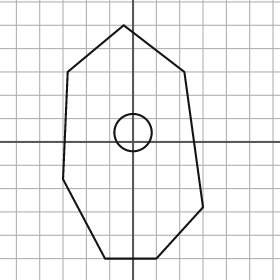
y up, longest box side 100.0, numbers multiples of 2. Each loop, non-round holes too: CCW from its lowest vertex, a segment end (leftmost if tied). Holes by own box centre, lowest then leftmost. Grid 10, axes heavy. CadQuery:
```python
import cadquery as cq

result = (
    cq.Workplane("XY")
    .moveTo(-12.0, -50.0)
    .lineTo(10.0, -50.0)
    .lineTo(30.0, -28.0)
    .lineTo(22.0, 30.0)
    .lineTo(-4.0, 50.0)
    .lineTo(-28.0, 30.0)
    .lineTo(-30.0, -16.0)
    .close()
    .moveTo(0.0, 4.0)
    .circle(8.0)
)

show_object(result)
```